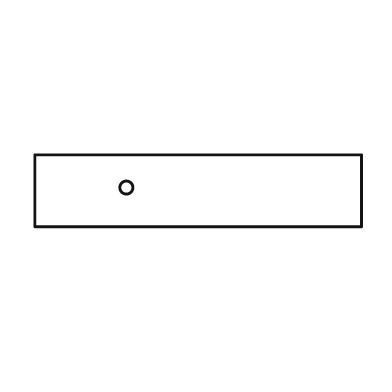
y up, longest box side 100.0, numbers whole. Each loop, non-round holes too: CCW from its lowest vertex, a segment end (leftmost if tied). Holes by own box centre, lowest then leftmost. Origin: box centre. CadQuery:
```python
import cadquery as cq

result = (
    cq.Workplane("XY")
    .moveTo(-50.0, -11.0)
    .lineTo(50.0, -11.0)
    .lineTo(50.0, 11.0)
    .lineTo(-50.0, 11.0)
    .close()
    .moveTo(-22.0, 1.0)
    .circle(2.0)
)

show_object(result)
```